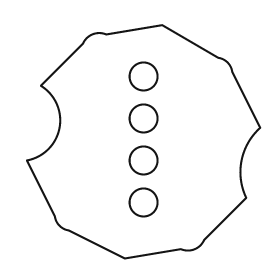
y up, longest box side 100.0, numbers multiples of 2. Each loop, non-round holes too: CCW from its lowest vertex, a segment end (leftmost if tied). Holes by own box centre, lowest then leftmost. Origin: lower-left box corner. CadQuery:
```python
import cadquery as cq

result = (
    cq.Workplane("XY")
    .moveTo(42.0, 0.0)
    .lineTo(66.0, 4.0)
    .threePointArc((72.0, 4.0), (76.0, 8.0))
    .lineTo(94.0, 26.0)
    .threePointArc((92.0, 42.0), (100.0, 56.0))
    .lineTo(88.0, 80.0)
    .threePointArc((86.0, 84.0), (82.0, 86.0))
    .lineTo(58.0, 100.0)
    .lineTo(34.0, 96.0)
    .threePointArc((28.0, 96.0), (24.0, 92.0))
    .lineTo(6.0, 74.0)
    .threePointArc((14.0, 56.0), (0.0, 42.0))
    .lineTo(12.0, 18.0)
    .threePointArc((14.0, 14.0), (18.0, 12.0))
    .close()
    .moveTo(50.0, 24.0)
    .circle(6.0)
    .moveTo(50.0, 42.0)
    .circle(6.0)
    .moveTo(50.0, 60.0)
    .circle(6.0)
    .moveTo(50.0, 78.0)
    .circle(6.0)
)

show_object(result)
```